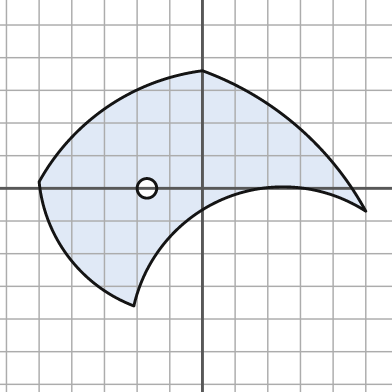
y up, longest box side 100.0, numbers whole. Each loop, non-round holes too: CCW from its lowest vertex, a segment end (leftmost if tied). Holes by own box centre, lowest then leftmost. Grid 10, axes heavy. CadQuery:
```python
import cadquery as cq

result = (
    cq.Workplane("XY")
    .moveTo(-21.0, -36.0)
    .threePointArc((7.0, -3.0), (50.0, -7.0))
    .threePointArc((29.0, 19.0), (0.0, 36.0))
    .threePointArc((-29.0, 25.0), (-50.0, 2.0))
    .threePointArc((-41.0, -21.0), (-21.0, -36.0))
    .close()
    .moveTo(-17.0, 0.0)
    .circle(3.0)
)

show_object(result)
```